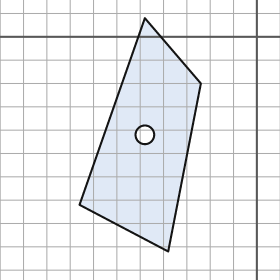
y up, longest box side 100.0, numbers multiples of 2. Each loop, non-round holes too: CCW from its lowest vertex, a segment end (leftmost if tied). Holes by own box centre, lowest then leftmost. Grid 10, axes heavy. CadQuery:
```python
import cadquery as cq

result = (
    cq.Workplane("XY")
    .moveTo(-38.0, -92.0)
    .lineTo(-24.0, -20.0)
    .lineTo(-48.0, 8.0)
    .lineTo(-76.0, -72.0)
    .close()
    .moveTo(-48.0, -42.0)
    .circle(4.0)
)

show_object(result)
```